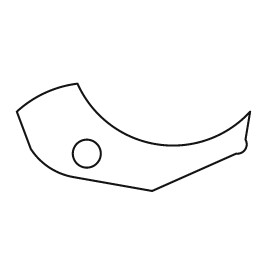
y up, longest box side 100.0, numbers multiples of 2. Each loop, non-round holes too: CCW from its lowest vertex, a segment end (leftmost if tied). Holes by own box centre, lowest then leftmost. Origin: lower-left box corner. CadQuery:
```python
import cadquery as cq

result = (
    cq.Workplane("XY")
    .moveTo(58.0, 0.0)
    .lineTo(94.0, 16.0)
    .threePointArc((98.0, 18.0), (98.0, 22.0))
    .lineTo(100.0, 34.0)
    .threePointArc((60.0, 20.0), (26.0, 46.0))
    .threePointArc((12.0, 42.0), (0.0, 34.0))
    .lineTo(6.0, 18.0)
    .threePointArc((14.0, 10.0), (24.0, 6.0))
    .close()
    .moveTo(30.0, 16.0)
    .circle(6.0)
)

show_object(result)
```